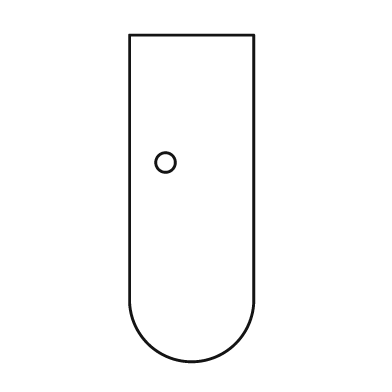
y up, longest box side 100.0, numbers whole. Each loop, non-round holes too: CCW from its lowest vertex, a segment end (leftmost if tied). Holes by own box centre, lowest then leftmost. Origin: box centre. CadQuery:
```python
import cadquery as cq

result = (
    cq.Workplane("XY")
    .moveTo(-19.0, -32.0)
    .threePointArc((0.0, -50.0), (19.0, -32.0))
    .lineTo(19.0, 50.0)
    .lineTo(-19.0, 50.0)
    .close()
    .moveTo(-8.0, 11.0)
    .circle(3.0)
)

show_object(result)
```